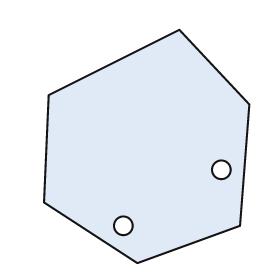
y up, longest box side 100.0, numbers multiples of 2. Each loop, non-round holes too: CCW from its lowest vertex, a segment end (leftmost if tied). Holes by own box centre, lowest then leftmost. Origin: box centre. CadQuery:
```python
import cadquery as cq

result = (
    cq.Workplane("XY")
    .moveTo(-4.0, -50.0)
    .lineTo(40.0, -34.0)
    .lineTo(44.0, 18.0)
    .lineTo(14.0, 50.0)
    .lineTo(-42.0, 22.0)
    .lineTo(-44.0, -24.0)
    .close()
    .moveTo(-10.0, -34.0)
    .circle(4.0)
    .moveTo(32.0, -10.0)
    .circle(4.0)
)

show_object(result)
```